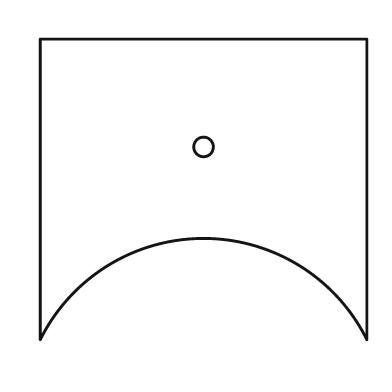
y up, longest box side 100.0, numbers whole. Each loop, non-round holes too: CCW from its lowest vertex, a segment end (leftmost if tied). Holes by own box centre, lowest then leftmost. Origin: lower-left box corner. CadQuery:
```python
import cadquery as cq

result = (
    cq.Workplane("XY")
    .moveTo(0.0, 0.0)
    .threePointArc((50.0, 31.0), (100.0, 0.0))
    .lineTo(100.0, 92.0)
    .lineTo(0.0, 92.0)
    .close()
    .moveTo(50.0, 59.0)
    .circle(3.0)
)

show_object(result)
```